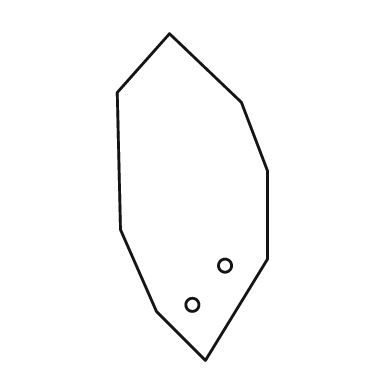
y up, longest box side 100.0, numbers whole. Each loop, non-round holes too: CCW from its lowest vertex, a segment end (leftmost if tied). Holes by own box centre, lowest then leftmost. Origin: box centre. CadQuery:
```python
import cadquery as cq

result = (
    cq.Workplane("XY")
    .moveTo(4.0, -50.0)
    .lineTo(23.0, -19.0)
    .lineTo(23.0, 8.0)
    .lineTo(15.0, 29.0)
    .lineTo(-7.0, 50.0)
    .lineTo(-23.0, 32.0)
    .lineTo(-22.0, -10.0)
    .lineTo(-11.0, -35.0)
    .close()
    .moveTo(0.0, -33.0)
    .circle(2.0)
    .moveTo(10.0, -21.0)
    .circle(2.0)
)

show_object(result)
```